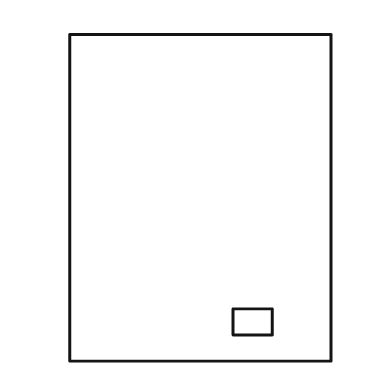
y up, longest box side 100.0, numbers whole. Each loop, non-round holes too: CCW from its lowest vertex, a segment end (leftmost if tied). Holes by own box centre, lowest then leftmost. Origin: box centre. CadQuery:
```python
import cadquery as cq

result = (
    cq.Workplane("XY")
    .moveTo(-40.0, -50.0)
    .lineTo(40.0, -50.0)
    .lineTo(40.0, 50.0)
    .lineTo(-40.0, 50.0)
    .close()
    .moveTo(10.0, -42.0)
    .lineTo(22.0, -42.0)
    .lineTo(22.0, -34.0)
    .lineTo(10.0, -34.0)
    .close()
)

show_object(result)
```